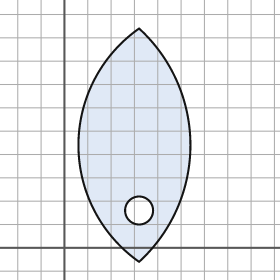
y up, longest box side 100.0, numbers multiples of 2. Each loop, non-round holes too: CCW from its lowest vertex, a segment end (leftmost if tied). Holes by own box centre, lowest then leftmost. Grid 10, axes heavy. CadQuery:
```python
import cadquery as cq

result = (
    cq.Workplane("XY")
    .moveTo(32.0, -6.0)
    .threePointArc((54.0, 44.0), (32.0, 94.0))
    .threePointArc((6.0, 44.0), (32.0, -6.0))
    .close()
    .moveTo(32.0, 16.0)
    .circle(6.0)
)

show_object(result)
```